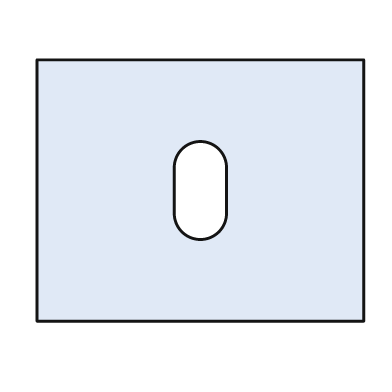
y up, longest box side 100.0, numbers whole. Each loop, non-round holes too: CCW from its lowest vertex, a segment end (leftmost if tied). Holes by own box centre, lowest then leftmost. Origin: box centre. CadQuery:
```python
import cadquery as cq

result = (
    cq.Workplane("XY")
    .moveTo(-50.0, -40.0)
    .lineTo(50.0, -40.0)
    .lineTo(50.0, 40.0)
    .lineTo(-50.0, 40.0)
    .close()
    .moveTo(-8.0, -7.0)
    .threePointArc((0.0, -15.0), (8.0, -7.0))
    .lineTo(8.0, 7.0)
    .threePointArc((0.0, 15.0), (-8.0, 7.0))
    .close()
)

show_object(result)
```